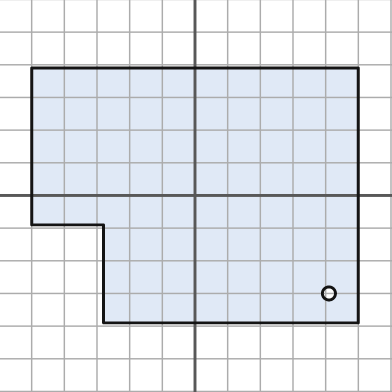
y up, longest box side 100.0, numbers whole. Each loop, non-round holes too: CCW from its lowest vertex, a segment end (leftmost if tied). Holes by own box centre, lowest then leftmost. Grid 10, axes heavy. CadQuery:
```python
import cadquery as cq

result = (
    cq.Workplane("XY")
    .moveTo(-28.0, -39.0)
    .lineTo(50.0, -39.0)
    .lineTo(50.0, 39.0)
    .lineTo(-50.0, 39.0)
    .lineTo(-50.0, -9.0)
    .lineTo(-28.0, -9.0)
    .close()
    .moveTo(41.0, -30.0)
    .circle(2.0)
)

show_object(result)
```